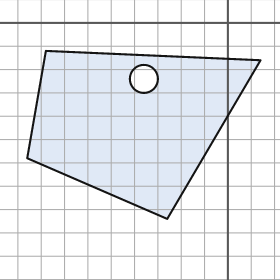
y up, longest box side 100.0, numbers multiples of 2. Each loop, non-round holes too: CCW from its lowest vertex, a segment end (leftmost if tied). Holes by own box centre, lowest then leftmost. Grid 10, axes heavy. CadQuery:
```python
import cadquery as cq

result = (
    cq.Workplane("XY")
    .moveTo(-26.0, -84.0)
    .lineTo(14.0, -16.0)
    .lineTo(-78.0, -12.0)
    .lineTo(-86.0, -58.0)
    .close()
    .moveTo(-36.0, -24.0)
    .circle(6.0)
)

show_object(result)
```